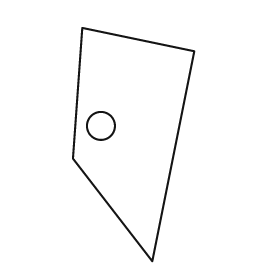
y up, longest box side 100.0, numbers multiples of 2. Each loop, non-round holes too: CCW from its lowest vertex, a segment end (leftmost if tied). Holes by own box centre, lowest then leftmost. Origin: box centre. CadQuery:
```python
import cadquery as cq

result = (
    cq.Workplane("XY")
    .moveTo(8.0, -50.0)
    .lineTo(26.0, 40.0)
    .lineTo(-22.0, 50.0)
    .lineTo(-26.0, -6.0)
    .close()
    .moveTo(-14.0, 8.0)
    .circle(6.0)
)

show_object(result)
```